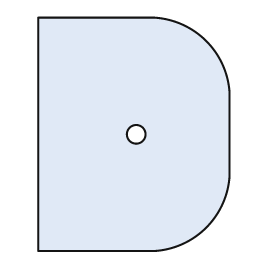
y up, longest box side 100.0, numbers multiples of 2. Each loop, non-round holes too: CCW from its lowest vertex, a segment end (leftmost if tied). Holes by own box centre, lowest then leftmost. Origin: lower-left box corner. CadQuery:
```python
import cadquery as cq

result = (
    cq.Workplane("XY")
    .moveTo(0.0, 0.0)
    .lineTo(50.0, 0.0)
    .threePointArc((72.0, 10.0), (82.0, 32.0))
    .lineTo(82.0, 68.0)
    .threePointArc((72.0, 90.0), (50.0, 100.0))
    .lineTo(0.0, 100.0)
    .close()
    .moveTo(42.0, 50.0)
    .circle(4.0)
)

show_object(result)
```